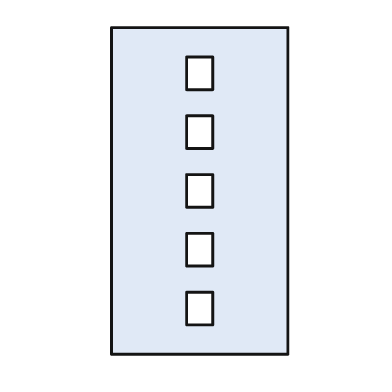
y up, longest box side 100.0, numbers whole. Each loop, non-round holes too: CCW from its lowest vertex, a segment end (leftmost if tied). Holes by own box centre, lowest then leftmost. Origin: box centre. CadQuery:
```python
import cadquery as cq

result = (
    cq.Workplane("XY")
    .moveTo(-27.0, -50.0)
    .lineTo(27.0, -50.0)
    .lineTo(27.0, 50.0)
    .lineTo(-27.0, 50.0)
    .close()
    .moveTo(-4.0, -41.0)
    .lineTo(4.0, -41.0)
    .lineTo(4.0, -31.0)
    .lineTo(-4.0, -31.0)
    .close()
    .moveTo(-4.0, -23.0)
    .lineTo(4.0, -23.0)
    .lineTo(4.0, -13.0)
    .lineTo(-4.0, -13.0)
    .close()
    .moveTo(-4.0, -5.0)
    .lineTo(4.0, -5.0)
    .lineTo(4.0, 5.0)
    .lineTo(-4.0, 5.0)
    .close()
    .moveTo(-4.0, 13.0)
    .lineTo(4.0, 13.0)
    .lineTo(4.0, 23.0)
    .lineTo(-4.0, 23.0)
    .close()
    .moveTo(-4.0, 31.0)
    .lineTo(4.0, 31.0)
    .lineTo(4.0, 41.0)
    .lineTo(-4.0, 41.0)
    .close()
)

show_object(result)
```